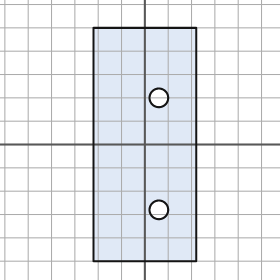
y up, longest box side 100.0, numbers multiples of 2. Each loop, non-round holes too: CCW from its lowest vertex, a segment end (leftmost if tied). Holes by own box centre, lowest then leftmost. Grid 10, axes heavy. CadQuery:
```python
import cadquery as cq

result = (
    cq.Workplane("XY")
    .moveTo(-22.0, -50.0)
    .lineTo(22.0, -50.0)
    .lineTo(22.0, 50.0)
    .lineTo(-22.0, 50.0)
    .close()
    .moveTo(6.0, -28.0)
    .circle(4.0)
    .moveTo(6.0, 20.0)
    .circle(4.0)
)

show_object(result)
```